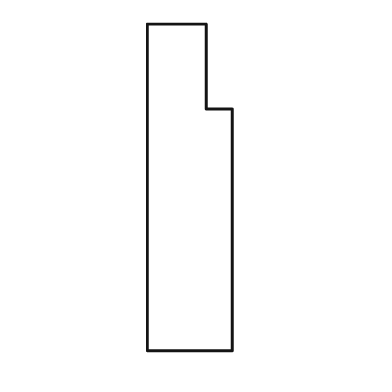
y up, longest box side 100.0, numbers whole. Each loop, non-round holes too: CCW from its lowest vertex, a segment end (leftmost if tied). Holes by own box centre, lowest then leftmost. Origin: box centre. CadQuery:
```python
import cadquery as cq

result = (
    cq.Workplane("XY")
    .moveTo(-13.0, -50.0)
    .lineTo(13.0, -50.0)
    .lineTo(13.0, 24.0)
    .lineTo(5.0, 24.0)
    .lineTo(5.0, 50.0)
    .lineTo(-13.0, 50.0)
    .close()
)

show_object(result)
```